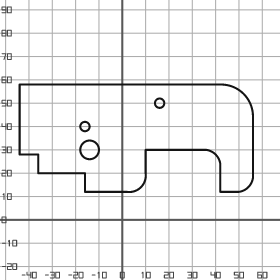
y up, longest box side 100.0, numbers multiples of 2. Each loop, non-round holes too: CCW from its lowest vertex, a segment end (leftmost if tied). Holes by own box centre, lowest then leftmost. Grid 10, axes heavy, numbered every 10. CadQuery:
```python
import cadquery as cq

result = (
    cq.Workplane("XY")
    .moveTo(-16.0, 12.0)
    .lineTo(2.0, 12.0)
    .threePointArc((8.0, 14.0), (10.0, 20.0))
    .lineTo(10.0, 30.0)
    .lineTo(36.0, 30.0)
    .threePointArc((40.0, 28.0), (42.0, 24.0))
    .lineTo(42.0, 12.0)
    .lineTo(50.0, 12.0)
    .threePointArc((54.0, 14.0), (56.0, 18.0))
    .lineTo(56.0, 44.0)
    .threePointArc((52.0, 54.0), (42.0, 58.0))
    .lineTo(-44.0, 58.0)
    .lineTo(-44.0, 28.0)
    .lineTo(-36.0, 28.0)
    .lineTo(-36.0, 20.0)
    .lineTo(-16.0, 20.0)
    .close()
    .moveTo(-14.0, 30.0)
    .circle(4.0)
    .moveTo(-16.0, 40.0)
    .circle(2.0)
    .moveTo(16.0, 50.0)
    .circle(2.0)
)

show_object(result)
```